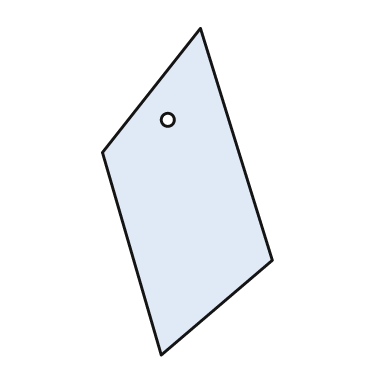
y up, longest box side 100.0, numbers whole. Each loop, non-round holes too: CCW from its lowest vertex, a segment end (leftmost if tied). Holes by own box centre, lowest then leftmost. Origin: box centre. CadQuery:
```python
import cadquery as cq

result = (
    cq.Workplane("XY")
    .moveTo(-8.0, -50.0)
    .lineTo(26.0, -21.0)
    .lineTo(4.0, 50.0)
    .lineTo(-26.0, 12.0)
    .close()
    .moveTo(-6.0, 22.0)
    .circle(2.0)
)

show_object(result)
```